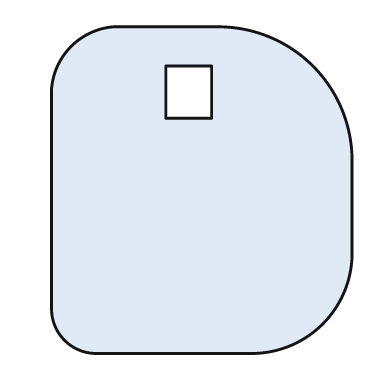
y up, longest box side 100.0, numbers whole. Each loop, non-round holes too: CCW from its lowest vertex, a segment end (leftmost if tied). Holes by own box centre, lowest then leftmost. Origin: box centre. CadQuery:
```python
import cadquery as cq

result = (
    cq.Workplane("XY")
    .moveTo(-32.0, -50.0)
    .lineTo(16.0, -50.0)
    .threePointArc((37.0, -41.0), (46.0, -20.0))
    .lineTo(46.0, 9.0)
    .threePointArc((34.0, 38.0), (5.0, 50.0))
    .lineTo(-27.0, 50.0)
    .threePointArc((-40.0, 44.0), (-46.0, 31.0))
    .lineTo(-46.0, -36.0)
    .threePointArc((-42.0, -46.0), (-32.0, -50.0))
    .close()
    .moveTo(-11.0, 22.0)
    .lineTo(3.0, 22.0)
    .lineTo(3.0, 38.0)
    .lineTo(-11.0, 38.0)
    .close()
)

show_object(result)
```